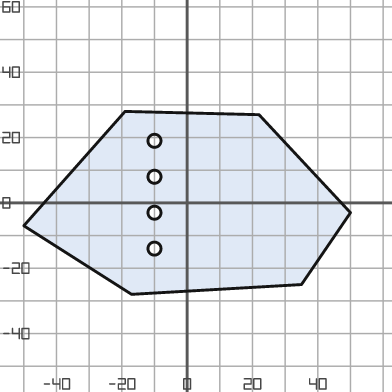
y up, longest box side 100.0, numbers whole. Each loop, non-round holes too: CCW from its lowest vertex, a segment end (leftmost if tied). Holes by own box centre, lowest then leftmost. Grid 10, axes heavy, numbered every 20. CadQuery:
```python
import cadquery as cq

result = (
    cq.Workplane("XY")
    .moveTo(-17.0, -28.0)
    .lineTo(35.0, -25.0)
    .lineTo(50.0, -3.0)
    .lineTo(22.0, 27.0)
    .lineTo(-19.0, 28.0)
    .lineTo(-50.0, -7.0)
    .close()
    .moveTo(-10.0, -14.0)
    .circle(2.0)
    .moveTo(-10.0, -3.0)
    .circle(2.0)
    .moveTo(-10.0, 8.0)
    .circle(2.0)
    .moveTo(-10.0, 19.0)
    .circle(2.0)
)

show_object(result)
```